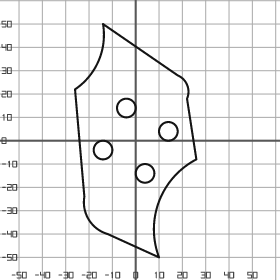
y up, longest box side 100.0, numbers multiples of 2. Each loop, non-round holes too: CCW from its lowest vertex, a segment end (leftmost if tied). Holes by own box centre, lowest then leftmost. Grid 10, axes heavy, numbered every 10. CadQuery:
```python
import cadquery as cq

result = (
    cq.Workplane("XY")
    .moveTo(10.0, -50.0)
    .threePointArc((10.0, -26.0), (26.0, -8.0))
    .lineTo(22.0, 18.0)
    .threePointArc((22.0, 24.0), (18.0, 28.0))
    .lineTo(-14.0, 50.0)
    .threePointArc((-16.0, 34.0), (-26.0, 22.0))
    .lineTo(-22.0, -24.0)
    .threePointArc((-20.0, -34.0), (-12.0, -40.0))
    .close()
    .moveTo(4.0, -14.0)
    .circle(4.0)
    .moveTo(-14.0, -4.0)
    .circle(4.0)
    .moveTo(14.0, 4.0)
    .circle(4.0)
    .moveTo(-4.0, 14.0)
    .circle(4.0)
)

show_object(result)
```